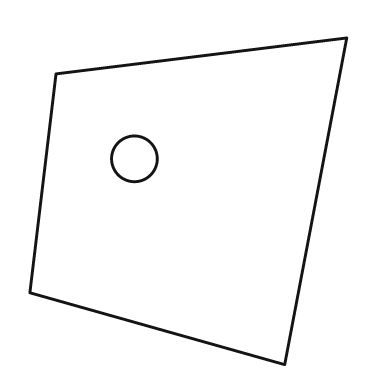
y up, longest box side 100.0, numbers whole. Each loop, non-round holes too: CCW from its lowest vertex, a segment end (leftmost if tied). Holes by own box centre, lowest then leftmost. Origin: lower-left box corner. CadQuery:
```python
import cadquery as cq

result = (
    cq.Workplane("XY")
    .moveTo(78.0, 0.0)
    .lineTo(97.0, 100.0)
    .lineTo(8.0, 89.0)
    .lineTo(0.0, 22.0)
    .close()
    .moveTo(32.0, 63.0)
    .circle(7.0)
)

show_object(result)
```